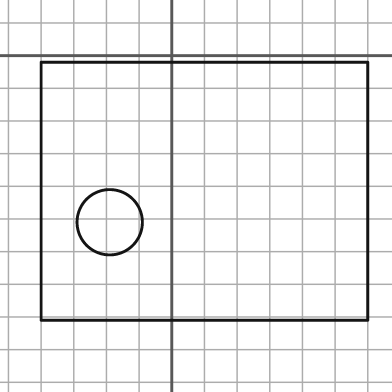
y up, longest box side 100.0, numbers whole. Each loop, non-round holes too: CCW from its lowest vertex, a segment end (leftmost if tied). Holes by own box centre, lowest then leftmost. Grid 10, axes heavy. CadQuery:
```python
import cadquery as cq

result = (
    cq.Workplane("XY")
    .moveTo(-40.0, -81.0)
    .lineTo(60.0, -81.0)
    .lineTo(60.0, -2.0)
    .lineTo(-40.0, -2.0)
    .close()
    .moveTo(-19.0, -51.0)
    .circle(10.0)
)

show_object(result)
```